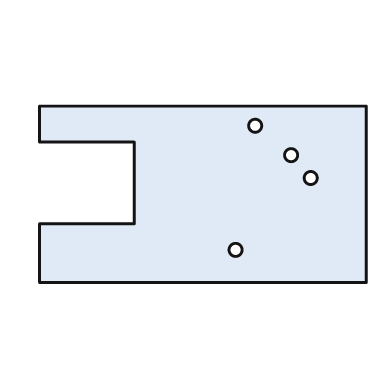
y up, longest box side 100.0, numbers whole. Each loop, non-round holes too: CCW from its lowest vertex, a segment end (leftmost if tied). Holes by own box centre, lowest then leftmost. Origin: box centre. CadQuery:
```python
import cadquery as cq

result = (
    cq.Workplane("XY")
    .moveTo(-50.0, -27.0)
    .lineTo(50.0, -27.0)
    .lineTo(50.0, 27.0)
    .lineTo(-50.0, 27.0)
    .lineTo(-50.0, 16.0)
    .lineTo(-21.0, 16.0)
    .lineTo(-21.0, -9.0)
    .lineTo(-50.0, -9.0)
    .close()
    .moveTo(10.0, -17.0)
    .circle(2.0)
    .moveTo(33.0, 5.0)
    .circle(2.0)
    .moveTo(27.0, 12.0)
    .circle(2.0)
    .moveTo(16.0, 21.0)
    .circle(2.0)
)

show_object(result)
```